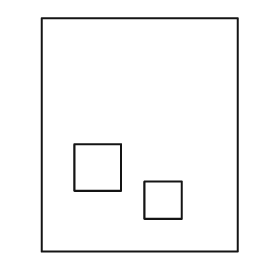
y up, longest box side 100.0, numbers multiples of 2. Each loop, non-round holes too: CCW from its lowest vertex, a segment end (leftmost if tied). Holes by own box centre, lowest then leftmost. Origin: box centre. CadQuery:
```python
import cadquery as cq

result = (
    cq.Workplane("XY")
    .moveTo(-42.0, -50.0)
    .lineTo(42.0, -50.0)
    .lineTo(42.0, 50.0)
    .lineTo(-42.0, 50.0)
    .close()
    .moveTo(2.0, -36.0)
    .lineTo(18.0, -36.0)
    .lineTo(18.0, -20.0)
    .lineTo(2.0, -20.0)
    .close()
    .moveTo(-28.0, -24.0)
    .lineTo(-8.0, -24.0)
    .lineTo(-8.0, -4.0)
    .lineTo(-28.0, -4.0)
    .close()
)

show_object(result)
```